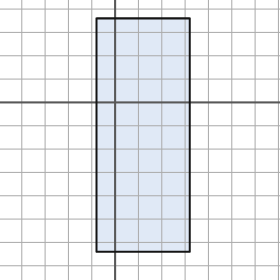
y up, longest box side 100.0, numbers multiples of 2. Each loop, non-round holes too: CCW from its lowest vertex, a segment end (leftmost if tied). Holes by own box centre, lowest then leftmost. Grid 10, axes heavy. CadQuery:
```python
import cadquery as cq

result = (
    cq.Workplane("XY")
    .moveTo(-8.0, -64.0)
    .lineTo(32.0, -64.0)
    .lineTo(32.0, 36.0)
    .lineTo(-8.0, 36.0)
    .close()
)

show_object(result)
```